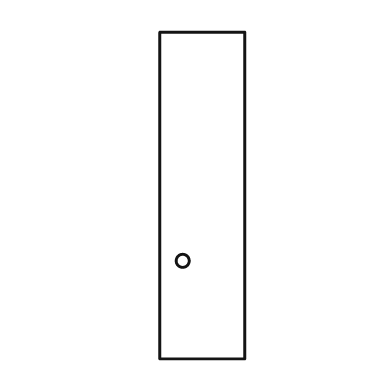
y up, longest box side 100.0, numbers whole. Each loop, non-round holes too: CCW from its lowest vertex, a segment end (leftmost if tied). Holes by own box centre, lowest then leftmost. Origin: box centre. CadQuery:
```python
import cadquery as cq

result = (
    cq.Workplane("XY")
    .moveTo(-13.0, -50.0)
    .lineTo(13.0, -50.0)
    .lineTo(13.0, 50.0)
    .lineTo(-13.0, 50.0)
    .close()
    .moveTo(-6.0, -20.0)
    .circle(2.0)
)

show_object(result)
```